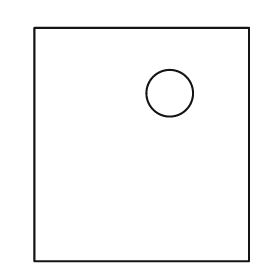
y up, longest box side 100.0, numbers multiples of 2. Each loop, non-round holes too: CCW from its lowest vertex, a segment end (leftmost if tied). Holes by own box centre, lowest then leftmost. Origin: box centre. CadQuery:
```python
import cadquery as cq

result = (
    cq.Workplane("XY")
    .moveTo(-46.0, -50.0)
    .lineTo(46.0, -50.0)
    .lineTo(46.0, 50.0)
    .lineTo(-46.0, 50.0)
    .close()
    .moveTo(12.0, 22.0)
    .circle(10.0)
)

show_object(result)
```